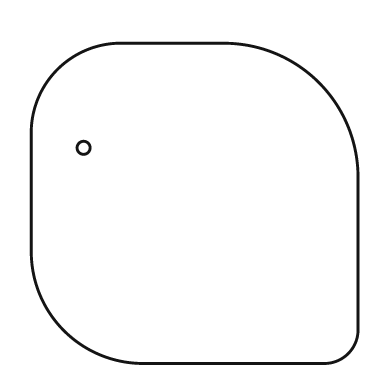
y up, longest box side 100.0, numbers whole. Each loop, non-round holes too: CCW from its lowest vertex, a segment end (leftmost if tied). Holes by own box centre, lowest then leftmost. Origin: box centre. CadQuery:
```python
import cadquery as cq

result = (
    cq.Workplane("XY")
    .moveTo(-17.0, -49.0)
    .lineTo(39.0, -49.0)
    .threePointArc((47.0, -46.0), (50.0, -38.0))
    .lineTo(50.0, 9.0)
    .threePointArc((38.0, 37.0), (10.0, 49.0))
    .lineTo(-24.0, 49.0)
    .threePointArc((-42.0, 41.0), (-50.0, 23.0))
    .lineTo(-50.0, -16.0)
    .threePointArc((-40.0, -39.0), (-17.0, -49.0))
    .close()
    .moveTo(-34.0, 17.0)
    .circle(2.0)
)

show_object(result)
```